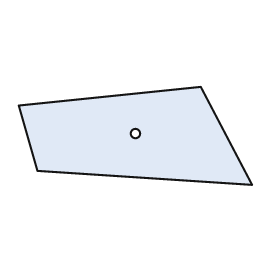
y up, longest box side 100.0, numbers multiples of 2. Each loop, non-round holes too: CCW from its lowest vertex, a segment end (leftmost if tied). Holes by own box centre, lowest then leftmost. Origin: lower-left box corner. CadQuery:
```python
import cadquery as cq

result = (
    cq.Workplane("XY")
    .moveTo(100.0, 0.0)
    .lineTo(78.0, 42.0)
    .lineTo(0.0, 34.0)
    .lineTo(8.0, 6.0)
    .close()
    .moveTo(50.0, 22.0)
    .circle(2.0)
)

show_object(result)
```